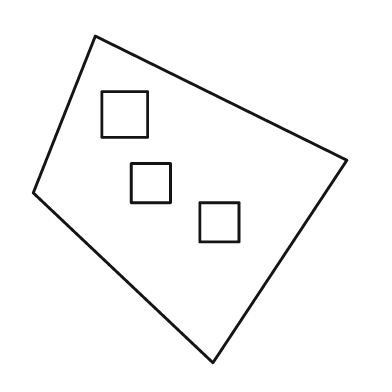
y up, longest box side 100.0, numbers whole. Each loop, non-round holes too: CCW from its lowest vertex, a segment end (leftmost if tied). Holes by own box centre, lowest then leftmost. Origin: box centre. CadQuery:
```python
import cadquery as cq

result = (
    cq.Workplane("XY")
    .moveTo(7.0, -50.0)
    .lineTo(48.0, 12.0)
    .lineTo(-29.0, 50.0)
    .lineTo(-48.0, 2.0)
    .close()
    .moveTo(3.0, -13.0)
    .lineTo(15.0, -13.0)
    .lineTo(15.0, -1.0)
    .lineTo(3.0, -1.0)
    .close()
    .moveTo(-18.0, -1.0)
    .lineTo(-6.0, -1.0)
    .lineTo(-6.0, 11.0)
    .lineTo(-18.0, 11.0)
    .close()
    .moveTo(-27.0, 19.0)
    .lineTo(-13.0, 19.0)
    .lineTo(-13.0, 33.0)
    .lineTo(-27.0, 33.0)
    .close()
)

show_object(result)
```